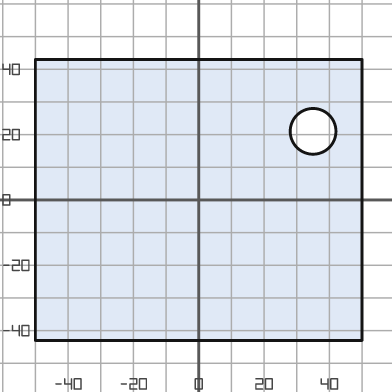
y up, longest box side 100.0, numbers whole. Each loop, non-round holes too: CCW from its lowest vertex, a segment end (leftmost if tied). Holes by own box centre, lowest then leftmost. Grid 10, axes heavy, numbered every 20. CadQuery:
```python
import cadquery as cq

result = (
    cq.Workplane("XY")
    .moveTo(-50.0, -43.0)
    .lineTo(50.0, -43.0)
    .lineTo(50.0, 43.0)
    .lineTo(-50.0, 43.0)
    .close()
    .moveTo(35.0, 21.0)
    .circle(7.0)
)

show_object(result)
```